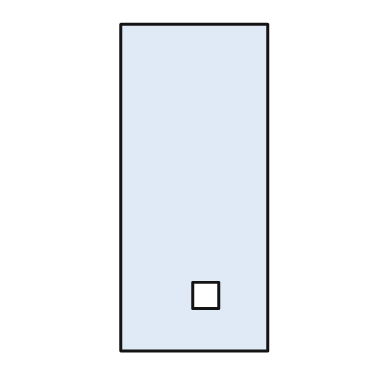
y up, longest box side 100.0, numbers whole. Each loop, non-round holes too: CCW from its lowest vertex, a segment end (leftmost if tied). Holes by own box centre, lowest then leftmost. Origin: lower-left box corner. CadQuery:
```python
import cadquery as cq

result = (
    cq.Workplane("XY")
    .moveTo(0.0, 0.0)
    .lineTo(45.0, 0.0)
    .lineTo(45.0, 100.0)
    .lineTo(0.0, 100.0)
    .close()
    .moveTo(22.0, 13.0)
    .lineTo(30.0, 13.0)
    .lineTo(30.0, 21.0)
    .lineTo(22.0, 21.0)
    .close()
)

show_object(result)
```